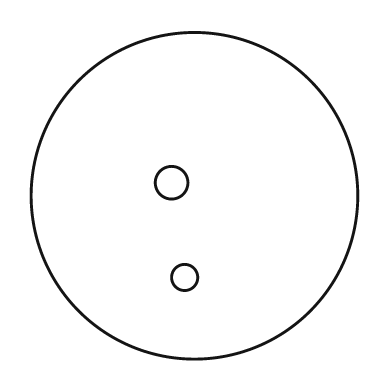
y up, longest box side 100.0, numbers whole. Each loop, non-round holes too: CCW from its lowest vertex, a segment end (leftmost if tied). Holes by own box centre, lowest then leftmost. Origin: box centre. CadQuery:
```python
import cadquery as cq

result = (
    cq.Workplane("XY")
    .moveTo(0.0, 0.0)
    .circle(50.0)
    .moveTo(-3.0, -25.0)
    .circle(4.0)
    .moveTo(-7.0, 4.0)
    .circle(5.0)
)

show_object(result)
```